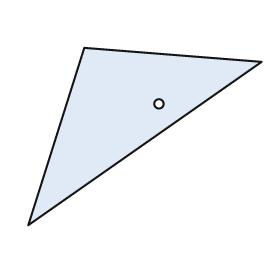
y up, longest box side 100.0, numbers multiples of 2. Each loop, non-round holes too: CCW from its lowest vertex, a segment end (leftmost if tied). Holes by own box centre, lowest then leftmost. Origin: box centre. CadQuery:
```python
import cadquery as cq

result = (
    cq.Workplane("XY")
    .moveTo(-50.0, -38.0)
    .lineTo(50.0, 32.0)
    .lineTo(-26.0, 38.0)
    .close()
    .moveTo(6.0, 14.0)
    .circle(2.0)
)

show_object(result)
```